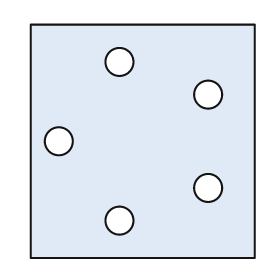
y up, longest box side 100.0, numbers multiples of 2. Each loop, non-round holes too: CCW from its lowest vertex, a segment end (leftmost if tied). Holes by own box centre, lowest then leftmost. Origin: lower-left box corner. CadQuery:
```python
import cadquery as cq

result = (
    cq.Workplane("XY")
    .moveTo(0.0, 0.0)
    .lineTo(96.0, 0.0)
    .lineTo(96.0, 100.0)
    .lineTo(0.0, 100.0)
    .close()
    .moveTo(38.0, 16.0)
    .circle(6.0)
    .moveTo(76.0, 30.0)
    .circle(6.0)
    .moveTo(12.0, 50.0)
    .circle(6.0)
    .moveTo(76.0, 70.0)
    .circle(6.0)
    .moveTo(38.0, 84.0)
    .circle(6.0)
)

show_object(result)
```